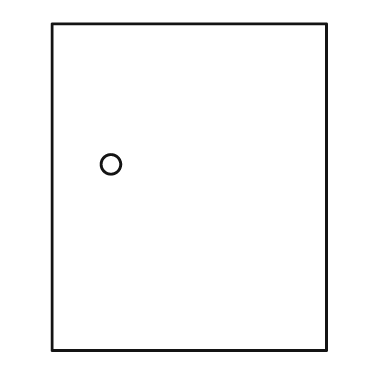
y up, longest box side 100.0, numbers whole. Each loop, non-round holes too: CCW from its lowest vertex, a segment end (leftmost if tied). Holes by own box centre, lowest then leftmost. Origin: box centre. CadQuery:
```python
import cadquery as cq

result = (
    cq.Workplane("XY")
    .moveTo(-42.0, -50.0)
    .lineTo(42.0, -50.0)
    .lineTo(42.0, 50.0)
    .lineTo(-42.0, 50.0)
    .close()
    .moveTo(-24.0, 7.0)
    .circle(3.0)
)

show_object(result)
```